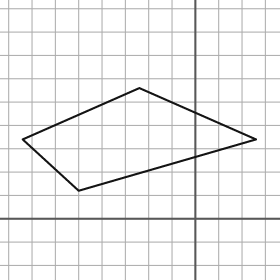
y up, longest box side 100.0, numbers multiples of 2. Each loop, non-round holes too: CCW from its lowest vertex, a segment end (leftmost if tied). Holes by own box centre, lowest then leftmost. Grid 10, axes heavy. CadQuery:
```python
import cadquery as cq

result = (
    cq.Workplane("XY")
    .moveTo(-50.0, 12.0)
    .lineTo(26.0, 34.0)
    .lineTo(-24.0, 56.0)
    .lineTo(-74.0, 34.0)
    .close()
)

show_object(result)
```